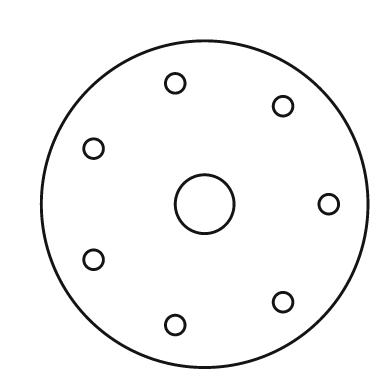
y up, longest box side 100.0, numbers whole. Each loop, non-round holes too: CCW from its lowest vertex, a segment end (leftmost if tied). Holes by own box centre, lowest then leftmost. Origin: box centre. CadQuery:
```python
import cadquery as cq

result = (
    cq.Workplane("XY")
    .moveTo(0.0, 0.0)
    .circle(50.0)
    .moveTo(-9.0, -37.0)
    .circle(3.0)
    .moveTo(24.0, -30.0)
    .circle(3.0)
    .moveTo(-34.0, -17.0)
    .circle(3.0)
    .moveTo(0.0, 0.0)
    .circle(9.0)
    .moveTo(38.0, 0.0)
    .circle(3.0)
    .moveTo(-34.0, 17.0)
    .circle(3.0)
    .moveTo(24.0, 30.0)
    .circle(3.0)
    .moveTo(-9.0, 37.0)
    .circle(3.0)
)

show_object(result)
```